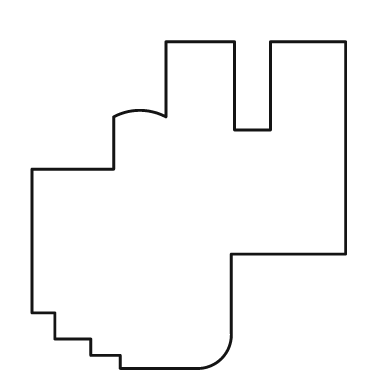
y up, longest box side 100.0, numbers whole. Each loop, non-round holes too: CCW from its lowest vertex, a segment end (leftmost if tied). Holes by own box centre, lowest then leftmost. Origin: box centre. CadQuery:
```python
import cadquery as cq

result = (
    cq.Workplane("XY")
    .moveTo(-21.0, -50.0)
    .lineTo(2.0, -50.0)
    .threePointArc((10.0, -47.0), (13.0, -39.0))
    .lineTo(13.0, -15.0)
    .lineTo(48.0, -15.0)
    .lineTo(48.0, 50.0)
    .lineTo(25.0, 50.0)
    .lineTo(25.0, 23.0)
    .lineTo(14.0, 23.0)
    .lineTo(14.0, 50.0)
    .lineTo(-7.0, 50.0)
    .lineTo(-7.0, 27.0)
    .threePointArc((-15.0, 29.0), (-23.0, 27.0))
    .lineTo(-23.0, 11.0)
    .lineTo(-48.0, 11.0)
    .lineTo(-48.0, -33.0)
    .lineTo(-41.0, -33.0)
    .lineTo(-41.0, -41.0)
    .lineTo(-30.0, -41.0)
    .lineTo(-30.0, -46.0)
    .lineTo(-21.0, -46.0)
    .close()
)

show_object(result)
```